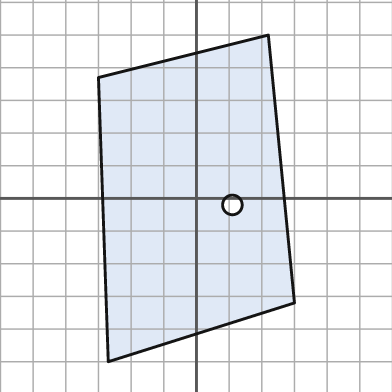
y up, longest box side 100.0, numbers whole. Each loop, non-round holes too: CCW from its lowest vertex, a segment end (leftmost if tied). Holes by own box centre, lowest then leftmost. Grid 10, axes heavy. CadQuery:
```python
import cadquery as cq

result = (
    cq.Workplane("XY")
    .moveTo(-27.0, -50.0)
    .lineTo(30.0, -32.0)
    .lineTo(22.0, 50.0)
    .lineTo(-30.0, 37.0)
    .close()
    .moveTo(11.0, -2.0)
    .circle(3.0)
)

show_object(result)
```